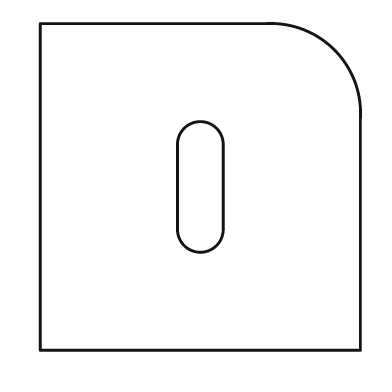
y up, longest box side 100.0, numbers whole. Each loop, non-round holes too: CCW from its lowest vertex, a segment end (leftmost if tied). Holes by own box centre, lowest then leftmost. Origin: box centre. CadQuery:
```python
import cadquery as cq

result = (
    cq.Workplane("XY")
    .moveTo(-49.0, -50.0)
    .lineTo(49.0, -50.0)
    .lineTo(49.0, 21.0)
    .threePointArc((41.0, 42.0), (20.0, 50.0))
    .lineTo(-49.0, 50.0)
    .close()
    .moveTo(-7.0, -13.0)
    .threePointArc((0.0, -20.0), (7.0, -13.0))
    .lineTo(7.0, 13.0)
    .threePointArc((0.0, 20.0), (-7.0, 13.0))
    .close()
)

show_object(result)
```